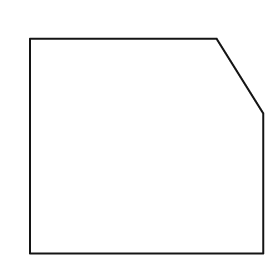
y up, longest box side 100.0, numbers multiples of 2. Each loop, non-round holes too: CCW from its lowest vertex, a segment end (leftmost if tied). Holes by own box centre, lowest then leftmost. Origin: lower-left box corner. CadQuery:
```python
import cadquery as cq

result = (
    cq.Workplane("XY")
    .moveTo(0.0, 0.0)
    .lineTo(100.0, 0.0)
    .lineTo(100.0, 60.0)
    .lineTo(80.0, 92.0)
    .lineTo(0.0, 92.0)
    .close()
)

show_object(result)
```